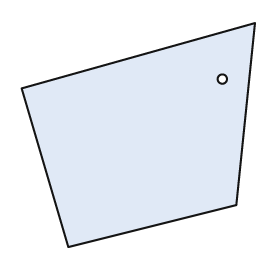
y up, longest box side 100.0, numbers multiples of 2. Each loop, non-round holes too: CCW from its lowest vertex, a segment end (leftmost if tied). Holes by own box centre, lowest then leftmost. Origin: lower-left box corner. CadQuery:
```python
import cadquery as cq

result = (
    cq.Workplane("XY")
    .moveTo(20.0, 0.0)
    .lineTo(92.0, 18.0)
    .lineTo(100.0, 96.0)
    .lineTo(0.0, 68.0)
    .close()
    .moveTo(86.0, 72.0)
    .circle(2.0)
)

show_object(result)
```